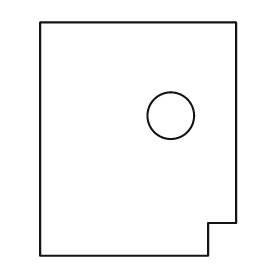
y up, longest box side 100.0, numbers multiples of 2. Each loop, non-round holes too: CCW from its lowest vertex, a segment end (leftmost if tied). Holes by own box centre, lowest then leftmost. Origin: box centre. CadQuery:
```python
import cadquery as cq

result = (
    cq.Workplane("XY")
    .moveTo(-42.0, -50.0)
    .lineTo(30.0, -50.0)
    .lineTo(30.0, -36.0)
    .lineTo(42.0, -36.0)
    .lineTo(42.0, 50.0)
    .lineTo(-42.0, 50.0)
    .close()
    .moveTo(14.0, 10.0)
    .circle(10.0)
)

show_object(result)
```